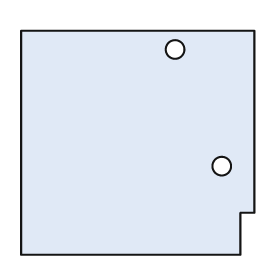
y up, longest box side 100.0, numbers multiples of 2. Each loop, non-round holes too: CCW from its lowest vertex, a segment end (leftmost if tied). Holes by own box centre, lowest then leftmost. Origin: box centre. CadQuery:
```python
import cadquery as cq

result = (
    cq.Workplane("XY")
    .moveTo(-50.0, -48.0)
    .lineTo(44.0, -48.0)
    .lineTo(44.0, -30.0)
    .lineTo(50.0, -30.0)
    .lineTo(50.0, 48.0)
    .lineTo(-50.0, 48.0)
    .close()
    .moveTo(36.0, -10.0)
    .circle(4.0)
    .moveTo(16.0, 40.0)
    .circle(4.0)
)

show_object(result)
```